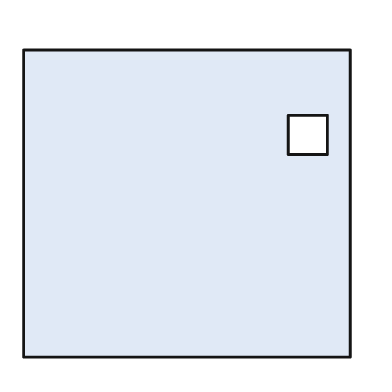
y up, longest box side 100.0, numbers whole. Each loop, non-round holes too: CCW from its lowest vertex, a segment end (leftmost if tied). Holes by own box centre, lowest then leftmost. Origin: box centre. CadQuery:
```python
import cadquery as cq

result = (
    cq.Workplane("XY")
    .moveTo(-50.0, -47.0)
    .lineTo(50.0, -47.0)
    .lineTo(50.0, 47.0)
    .lineTo(-50.0, 47.0)
    .close()
    .moveTo(31.0, 15.0)
    .lineTo(43.0, 15.0)
    .lineTo(43.0, 27.0)
    .lineTo(31.0, 27.0)
    .close()
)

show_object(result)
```